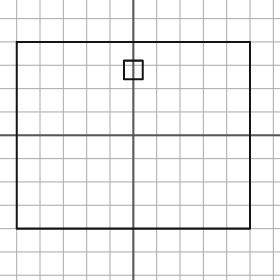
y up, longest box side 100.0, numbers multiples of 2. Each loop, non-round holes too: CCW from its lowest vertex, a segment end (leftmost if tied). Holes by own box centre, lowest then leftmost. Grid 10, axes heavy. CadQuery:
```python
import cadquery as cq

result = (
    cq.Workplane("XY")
    .moveTo(-50.0, -40.0)
    .lineTo(50.0, -40.0)
    .lineTo(50.0, 40.0)
    .lineTo(-50.0, 40.0)
    .close()
    .moveTo(-4.0, 24.0)
    .lineTo(4.0, 24.0)
    .lineTo(4.0, 32.0)
    .lineTo(-4.0, 32.0)
    .close()
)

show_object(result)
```